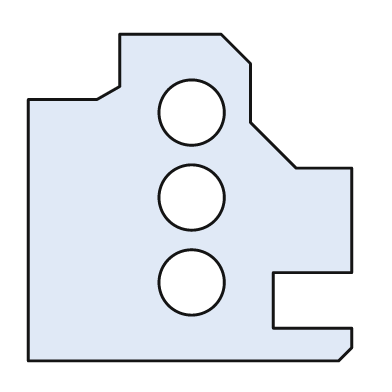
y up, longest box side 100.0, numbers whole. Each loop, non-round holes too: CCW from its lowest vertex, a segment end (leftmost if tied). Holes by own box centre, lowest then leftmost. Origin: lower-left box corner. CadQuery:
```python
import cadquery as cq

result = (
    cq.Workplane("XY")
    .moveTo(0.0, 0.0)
    .lineTo(95.0, 0.0)
    .lineTo(99.0, 4.0)
    .lineTo(99.0, 10.0)
    .lineTo(75.0, 10.0)
    .lineTo(75.0, 27.0)
    .lineTo(99.0, 27.0)
    .lineTo(99.0, 59.0)
    .lineTo(82.0, 59.0)
    .lineTo(68.0, 73.0)
    .lineTo(68.0, 91.0)
    .lineTo(59.0, 100.0)
    .lineTo(28.0, 100.0)
    .lineTo(28.0, 84.0)
    .lineTo(21.0, 80.0)
    .lineTo(0.0, 80.0)
    .close()
    .moveTo(50.0, 24.0)
    .circle(10.0)
    .moveTo(50.0, 50.0)
    .circle(10.0)
    .moveTo(50.0, 76.0)
    .circle(10.0)
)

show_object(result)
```